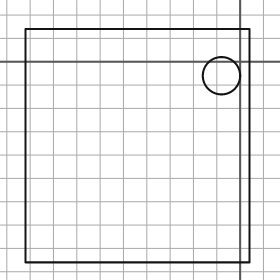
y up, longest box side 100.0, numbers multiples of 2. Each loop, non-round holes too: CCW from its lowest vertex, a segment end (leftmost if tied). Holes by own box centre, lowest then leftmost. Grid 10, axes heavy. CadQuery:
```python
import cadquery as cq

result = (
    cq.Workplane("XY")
    .moveTo(-92.0, -86.0)
    .lineTo(4.0, -86.0)
    .lineTo(4.0, 14.0)
    .lineTo(-92.0, 14.0)
    .close()
    .moveTo(-8.0, -6.0)
    .circle(8.0)
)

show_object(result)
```